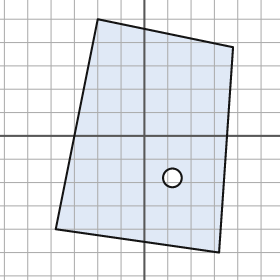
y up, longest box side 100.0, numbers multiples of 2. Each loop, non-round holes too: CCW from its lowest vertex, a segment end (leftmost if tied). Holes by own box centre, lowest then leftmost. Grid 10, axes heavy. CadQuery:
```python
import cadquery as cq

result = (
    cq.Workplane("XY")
    .moveTo(32.0, -50.0)
    .lineTo(38.0, 38.0)
    .lineTo(-20.0, 50.0)
    .lineTo(-38.0, -40.0)
    .close()
    .moveTo(12.0, -18.0)
    .circle(4.0)
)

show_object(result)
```